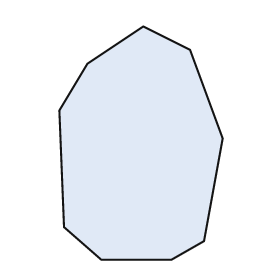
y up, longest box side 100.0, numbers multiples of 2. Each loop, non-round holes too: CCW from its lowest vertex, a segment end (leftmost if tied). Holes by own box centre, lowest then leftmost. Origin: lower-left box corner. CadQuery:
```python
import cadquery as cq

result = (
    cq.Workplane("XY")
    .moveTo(18.0, 0.0)
    .lineTo(48.0, 0.0)
    .lineTo(62.0, 8.0)
    .lineTo(70.0, 52.0)
    .lineTo(56.0, 90.0)
    .lineTo(36.0, 100.0)
    .lineTo(12.0, 84.0)
    .lineTo(0.0, 64.0)
    .lineTo(2.0, 14.0)
    .close()
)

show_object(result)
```